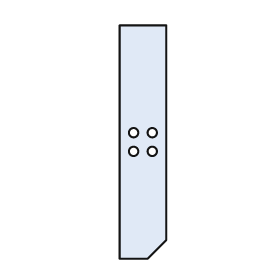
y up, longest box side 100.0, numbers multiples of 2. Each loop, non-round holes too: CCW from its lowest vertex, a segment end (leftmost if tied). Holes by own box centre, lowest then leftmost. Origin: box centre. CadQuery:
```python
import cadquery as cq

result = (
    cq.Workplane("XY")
    .moveTo(-10.0, -50.0)
    .lineTo(2.0, -50.0)
    .lineTo(10.0, -42.0)
    .lineTo(10.0, 50.0)
    .lineTo(-10.0, 50.0)
    .close()
    .moveTo(-4.0, -4.0)
    .circle(2.0)
    .moveTo(4.0, -4.0)
    .circle(2.0)
    .moveTo(-4.0, 4.0)
    .circle(2.0)
    .moveTo(4.0, 4.0)
    .circle(2.0)
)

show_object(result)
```